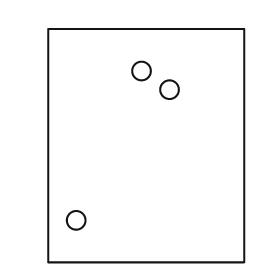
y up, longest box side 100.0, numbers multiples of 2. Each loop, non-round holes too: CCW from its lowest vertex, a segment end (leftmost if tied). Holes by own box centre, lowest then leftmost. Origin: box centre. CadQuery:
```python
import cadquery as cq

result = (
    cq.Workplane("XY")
    .moveTo(-42.0, -50.0)
    .lineTo(42.0, -50.0)
    .lineTo(42.0, 50.0)
    .lineTo(-42.0, 50.0)
    .close()
    .moveTo(-30.0, -32.0)
    .circle(4.0)
    .moveTo(10.0, 24.0)
    .circle(4.0)
    .moveTo(-2.0, 32.0)
    .circle(4.0)
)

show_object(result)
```